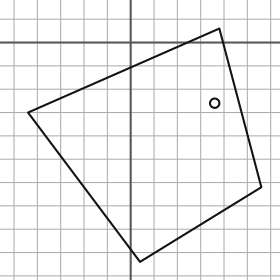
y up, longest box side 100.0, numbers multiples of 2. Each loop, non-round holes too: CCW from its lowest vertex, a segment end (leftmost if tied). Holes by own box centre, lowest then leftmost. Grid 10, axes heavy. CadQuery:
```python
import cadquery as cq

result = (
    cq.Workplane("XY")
    .moveTo(4.0, -94.0)
    .lineTo(56.0, -62.0)
    .lineTo(38.0, 6.0)
    .lineTo(-44.0, -30.0)
    .close()
    .moveTo(36.0, -26.0)
    .circle(2.0)
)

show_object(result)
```